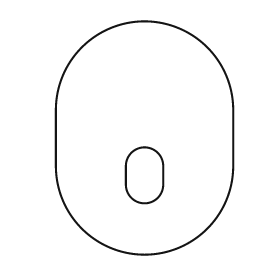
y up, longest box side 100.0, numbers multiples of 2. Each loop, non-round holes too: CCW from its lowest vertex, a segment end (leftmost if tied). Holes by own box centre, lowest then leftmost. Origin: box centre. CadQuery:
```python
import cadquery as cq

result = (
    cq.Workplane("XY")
    .moveTo(-38.0, -12.0)
    .threePointArc((0.0, -50.0), (38.0, -12.0))
    .lineTo(38.0, 12.0)
    .threePointArc((0.0, 50.0), (-38.0, 12.0))
    .close()
    .moveTo(-8.0, -20.0)
    .threePointArc((0.0, -28.0), (8.0, -20.0))
    .lineTo(8.0, -12.0)
    .threePointArc((0.0, -4.0), (-8.0, -12.0))
    .close()
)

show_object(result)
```